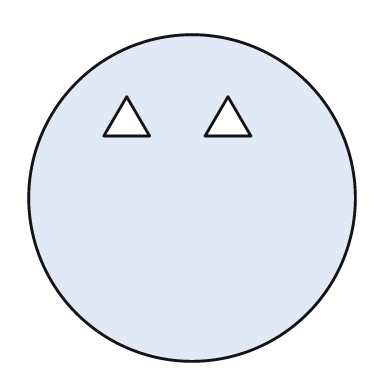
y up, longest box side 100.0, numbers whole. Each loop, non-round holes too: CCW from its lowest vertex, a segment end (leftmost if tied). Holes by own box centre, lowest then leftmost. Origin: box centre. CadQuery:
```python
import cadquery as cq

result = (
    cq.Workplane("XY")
    .moveTo(0.0, 0.0)
    .circle(50.0)
    .moveTo(-27.0, 19.0)
    .lineTo(-13.0, 19.0)
    .lineTo(-20.0, 31.0)
    .close()
    .moveTo(4.0, 19.0)
    .lineTo(18.0, 19.0)
    .lineTo(11.0, 31.0)
    .close()
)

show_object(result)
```